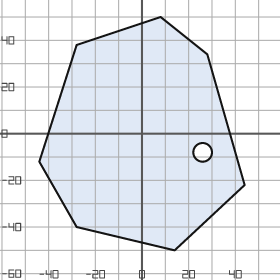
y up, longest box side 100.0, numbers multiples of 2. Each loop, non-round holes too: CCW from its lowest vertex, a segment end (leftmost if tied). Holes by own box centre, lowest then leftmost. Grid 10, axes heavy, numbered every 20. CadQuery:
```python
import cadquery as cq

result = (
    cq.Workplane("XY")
    .moveTo(14.0, -50.0)
    .lineTo(44.0, -22.0)
    .lineTo(28.0, 34.0)
    .lineTo(8.0, 50.0)
    .lineTo(-28.0, 38.0)
    .lineTo(-44.0, -12.0)
    .lineTo(-28.0, -40.0)
    .close()
    .moveTo(26.0, -8.0)
    .circle(4.0)
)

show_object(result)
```